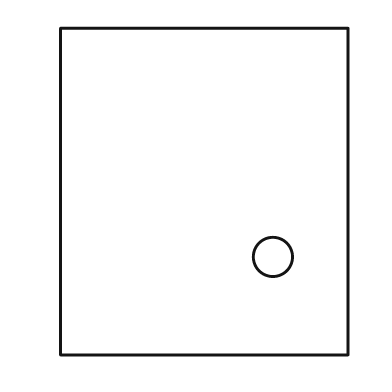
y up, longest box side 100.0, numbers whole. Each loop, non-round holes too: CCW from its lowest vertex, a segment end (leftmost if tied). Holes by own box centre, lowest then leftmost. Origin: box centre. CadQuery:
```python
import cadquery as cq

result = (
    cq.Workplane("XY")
    .moveTo(-44.0, -50.0)
    .lineTo(44.0, -50.0)
    .lineTo(44.0, 50.0)
    .lineTo(-44.0, 50.0)
    .close()
    .moveTo(21.0, -20.0)
    .circle(6.0)
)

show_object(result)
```